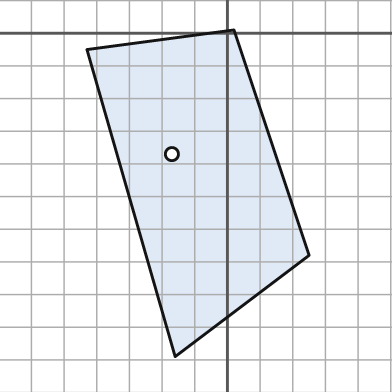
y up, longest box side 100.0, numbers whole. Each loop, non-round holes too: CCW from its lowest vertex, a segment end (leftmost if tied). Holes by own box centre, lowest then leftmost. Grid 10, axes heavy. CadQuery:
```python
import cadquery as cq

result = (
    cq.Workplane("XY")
    .moveTo(-16.0, -99.0)
    .lineTo(25.0, -68.0)
    .lineTo(2.0, 1.0)
    .lineTo(-43.0, -5.0)
    .close()
    .moveTo(-17.0, -37.0)
    .circle(2.0)
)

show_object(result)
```